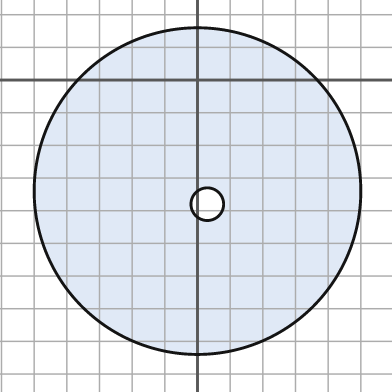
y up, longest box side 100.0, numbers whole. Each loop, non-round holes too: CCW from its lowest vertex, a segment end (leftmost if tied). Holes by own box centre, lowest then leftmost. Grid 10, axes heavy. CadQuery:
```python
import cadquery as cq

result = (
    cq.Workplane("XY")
    .moveTo(0.0, -34.0)
    .circle(50.0)
    .moveTo(3.0, -38.0)
    .circle(5.0)
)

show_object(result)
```